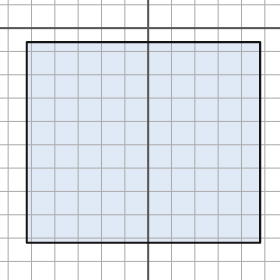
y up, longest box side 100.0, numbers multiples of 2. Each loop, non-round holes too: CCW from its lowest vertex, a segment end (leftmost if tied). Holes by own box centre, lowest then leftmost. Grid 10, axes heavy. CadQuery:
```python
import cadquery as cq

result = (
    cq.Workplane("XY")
    .moveTo(-52.0, -92.0)
    .lineTo(48.0, -92.0)
    .lineTo(48.0, -6.0)
    .lineTo(-52.0, -6.0)
    .close()
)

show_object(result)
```